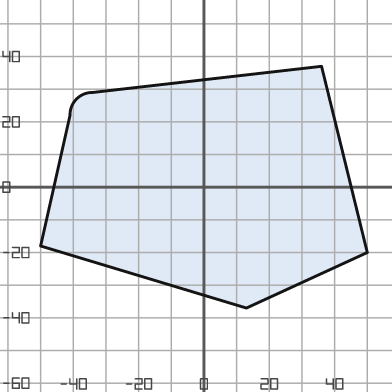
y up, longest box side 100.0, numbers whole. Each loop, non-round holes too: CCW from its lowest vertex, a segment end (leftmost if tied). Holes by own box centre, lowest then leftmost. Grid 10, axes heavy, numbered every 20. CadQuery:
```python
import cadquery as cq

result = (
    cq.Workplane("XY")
    .moveTo(13.0, -37.0)
    .lineTo(50.0, -20.0)
    .lineTo(36.0, 37.0)
    .lineTo(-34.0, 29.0)
    .threePointArc((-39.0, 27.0), (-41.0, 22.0))
    .lineTo(-50.0, -18.0)
    .close()
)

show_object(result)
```